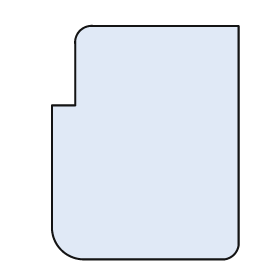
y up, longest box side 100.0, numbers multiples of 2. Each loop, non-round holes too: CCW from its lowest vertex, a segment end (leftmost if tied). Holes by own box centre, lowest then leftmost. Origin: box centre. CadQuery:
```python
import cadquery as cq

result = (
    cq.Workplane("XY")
    .moveTo(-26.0, -50.0)
    .lineTo(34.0, -50.0)
    .threePointArc((38.0, -48.0), (40.0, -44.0))
    .lineTo(40.0, 50.0)
    .lineTo(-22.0, 50.0)
    .threePointArc((-28.0, 48.0), (-30.0, 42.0))
    .lineTo(-30.0, 16.0)
    .lineTo(-40.0, 16.0)
    .lineTo(-40.0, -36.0)
    .threePointArc((-36.0, -46.0), (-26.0, -50.0))
    .close()
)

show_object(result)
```